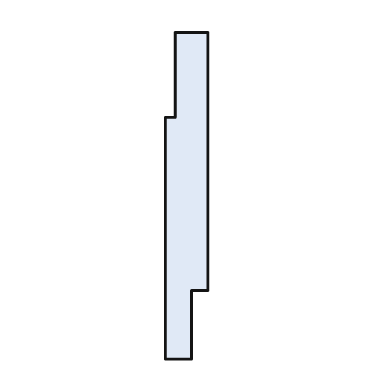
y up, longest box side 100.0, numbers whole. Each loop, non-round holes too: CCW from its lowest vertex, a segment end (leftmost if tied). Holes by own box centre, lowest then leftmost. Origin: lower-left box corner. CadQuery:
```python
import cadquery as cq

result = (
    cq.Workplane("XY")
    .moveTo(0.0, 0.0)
    .lineTo(8.0, 0.0)
    .lineTo(8.0, 21.0)
    .lineTo(13.0, 21.0)
    .lineTo(13.0, 100.0)
    .lineTo(3.0, 100.0)
    .lineTo(3.0, 74.0)
    .lineTo(0.0, 74.0)
    .close()
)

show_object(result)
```